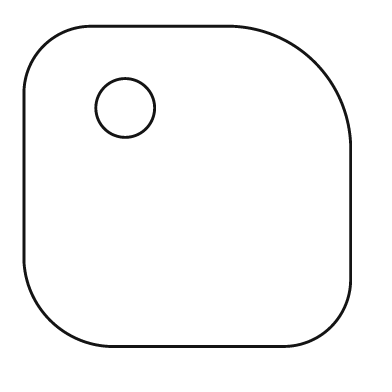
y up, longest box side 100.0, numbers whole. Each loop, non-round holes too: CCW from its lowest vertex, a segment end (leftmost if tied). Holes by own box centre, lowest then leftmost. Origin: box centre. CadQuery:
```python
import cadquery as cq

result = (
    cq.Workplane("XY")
    .moveTo(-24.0, -49.0)
    .lineTo(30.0, -49.0)
    .threePointArc((44.0, -43.0), (50.0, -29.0))
    .lineTo(50.0, 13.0)
    .threePointArc((39.0, 38.0), (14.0, 49.0))
    .lineTo(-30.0, 49.0)
    .threePointArc((-44.0, 43.0), (-50.0, 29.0))
    .lineTo(-50.0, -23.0)
    .threePointArc((-42.0, -41.0), (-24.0, -49.0))
    .close()
    .moveTo(-19.0, 24.0)
    .circle(9.0)
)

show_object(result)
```